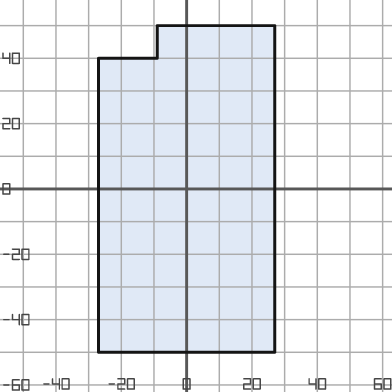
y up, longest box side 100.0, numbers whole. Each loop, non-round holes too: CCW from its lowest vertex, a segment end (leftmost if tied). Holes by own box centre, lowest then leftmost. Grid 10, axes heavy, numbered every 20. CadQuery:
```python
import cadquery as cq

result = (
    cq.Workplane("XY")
    .moveTo(-27.0, -50.0)
    .lineTo(27.0, -50.0)
    .lineTo(27.0, 50.0)
    .lineTo(-9.0, 50.0)
    .lineTo(-9.0, 40.0)
    .lineTo(-27.0, 40.0)
    .close()
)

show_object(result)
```